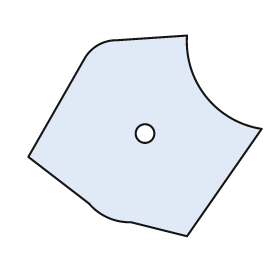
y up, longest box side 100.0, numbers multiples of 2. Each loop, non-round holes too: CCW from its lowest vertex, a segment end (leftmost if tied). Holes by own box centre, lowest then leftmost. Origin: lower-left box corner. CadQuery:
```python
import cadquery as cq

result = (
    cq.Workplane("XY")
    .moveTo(68.0, 0.0)
    .lineTo(100.0, 46.0)
    .threePointArc((76.0, 60.0), (68.0, 86.0))
    .lineTo(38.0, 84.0)
    .threePointArc((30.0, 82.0), (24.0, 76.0))
    .lineTo(0.0, 34.0)
    .lineTo(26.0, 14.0)
    .threePointArc((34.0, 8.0), (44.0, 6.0))
    .close()
    .moveTo(50.0, 44.0)
    .circle(4.0)
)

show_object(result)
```